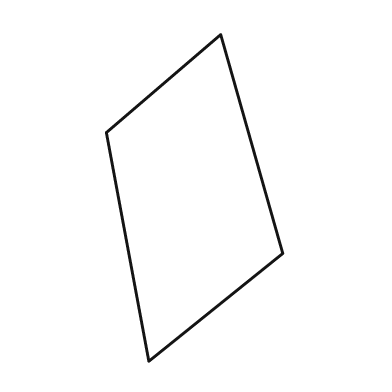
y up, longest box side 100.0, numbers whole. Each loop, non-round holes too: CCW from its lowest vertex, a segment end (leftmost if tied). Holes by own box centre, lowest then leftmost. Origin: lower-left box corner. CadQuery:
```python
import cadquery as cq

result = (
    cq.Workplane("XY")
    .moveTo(13.0, 0.0)
    .lineTo(54.0, 33.0)
    .lineTo(35.0, 100.0)
    .lineTo(0.0, 70.0)
    .close()
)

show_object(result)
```